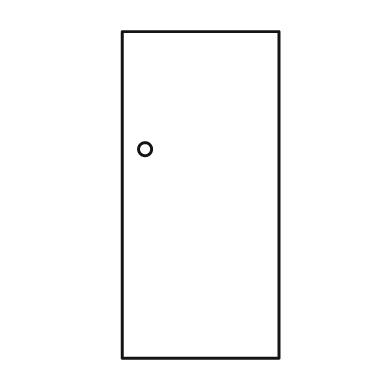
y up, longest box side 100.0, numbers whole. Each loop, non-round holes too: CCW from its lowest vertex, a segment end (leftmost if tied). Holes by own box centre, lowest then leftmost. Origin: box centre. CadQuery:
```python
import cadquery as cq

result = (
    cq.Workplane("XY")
    .moveTo(-24.0, -50.0)
    .lineTo(24.0, -50.0)
    .lineTo(24.0, 50.0)
    .lineTo(-24.0, 50.0)
    .close()
    .moveTo(-17.0, 14.0)
    .circle(2.0)
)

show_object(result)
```